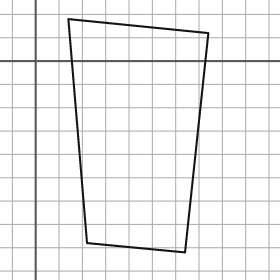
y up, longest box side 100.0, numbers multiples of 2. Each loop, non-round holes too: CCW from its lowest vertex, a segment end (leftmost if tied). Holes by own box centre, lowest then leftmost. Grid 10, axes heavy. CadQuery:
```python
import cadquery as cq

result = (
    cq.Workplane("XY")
    .moveTo(64.0, -82.0)
    .lineTo(74.0, 12.0)
    .lineTo(14.0, 18.0)
    .lineTo(22.0, -78.0)
    .close()
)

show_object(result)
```